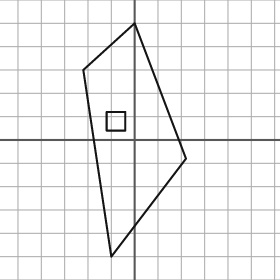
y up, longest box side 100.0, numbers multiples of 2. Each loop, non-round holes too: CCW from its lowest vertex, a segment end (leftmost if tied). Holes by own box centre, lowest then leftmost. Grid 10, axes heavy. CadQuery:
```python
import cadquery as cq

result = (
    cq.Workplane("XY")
    .moveTo(-10.0, -50.0)
    .lineTo(22.0, -8.0)
    .lineTo(0.0, 50.0)
    .lineTo(-22.0, 30.0)
    .close()
    .moveTo(-12.0, 4.0)
    .lineTo(-4.0, 4.0)
    .lineTo(-4.0, 12.0)
    .lineTo(-12.0, 12.0)
    .close()
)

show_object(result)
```